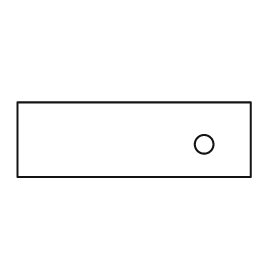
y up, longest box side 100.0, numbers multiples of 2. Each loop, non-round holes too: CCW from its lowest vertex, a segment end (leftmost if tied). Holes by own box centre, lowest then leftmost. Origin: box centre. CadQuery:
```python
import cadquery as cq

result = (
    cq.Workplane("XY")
    .moveTo(-50.0, -16.0)
    .lineTo(50.0, -16.0)
    .lineTo(50.0, 16.0)
    .lineTo(-50.0, 16.0)
    .close()
    .moveTo(30.0, -2.0)
    .circle(4.0)
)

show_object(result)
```